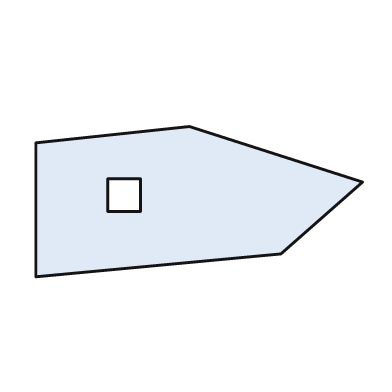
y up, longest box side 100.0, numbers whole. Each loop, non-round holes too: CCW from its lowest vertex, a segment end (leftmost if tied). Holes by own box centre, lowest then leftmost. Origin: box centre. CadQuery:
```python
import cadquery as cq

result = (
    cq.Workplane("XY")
    .moveTo(-50.0, -23.0)
    .lineTo(25.0, -16.0)
    .lineTo(50.0, 6.0)
    .lineTo(-3.0, 23.0)
    .lineTo(-50.0, 18.0)
    .close()
    .moveTo(-28.0, -3.0)
    .lineTo(-18.0, -3.0)
    .lineTo(-18.0, 7.0)
    .lineTo(-28.0, 7.0)
    .close()
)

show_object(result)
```